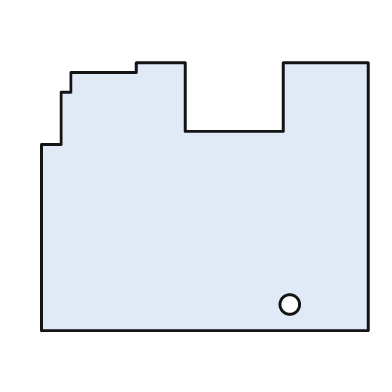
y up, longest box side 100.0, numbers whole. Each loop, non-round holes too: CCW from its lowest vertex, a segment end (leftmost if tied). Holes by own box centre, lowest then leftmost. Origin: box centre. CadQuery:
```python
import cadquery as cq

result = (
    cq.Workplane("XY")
    .moveTo(-50.0, -41.0)
    .lineTo(50.0, -41.0)
    .lineTo(50.0, 41.0)
    .lineTo(24.0, 41.0)
    .lineTo(24.0, 20.0)
    .lineTo(-6.0, 20.0)
    .lineTo(-6.0, 41.0)
    .lineTo(-21.0, 41.0)
    .lineTo(-21.0, 38.0)
    .lineTo(-41.0, 38.0)
    .lineTo(-41.0, 32.0)
    .lineTo(-44.0, 32.0)
    .lineTo(-44.0, 16.0)
    .lineTo(-50.0, 16.0)
    .close()
    .moveTo(26.0, -33.0)
    .circle(3.0)
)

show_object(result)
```